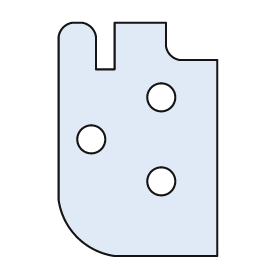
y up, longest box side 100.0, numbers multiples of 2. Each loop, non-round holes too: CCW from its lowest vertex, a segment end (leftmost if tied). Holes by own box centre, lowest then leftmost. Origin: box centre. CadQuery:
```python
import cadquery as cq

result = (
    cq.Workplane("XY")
    .moveTo(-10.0, -50.0)
    .lineTo(34.0, -50.0)
    .lineTo(34.0, 34.0)
    .lineTo(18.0, 34.0)
    .threePointArc((14.0, 36.0), (12.0, 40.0))
    .lineTo(12.0, 50.0)
    .lineTo(-10.0, 50.0)
    .lineTo(-10.0, 30.0)
    .lineTo(-18.0, 30.0)
    .lineTo(-18.0, 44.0)
    .threePointArc((-20.0, 48.0), (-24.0, 50.0))
    .lineTo(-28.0, 50.0)
    .threePointArc((-32.0, 48.0), (-34.0, 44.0))
    .lineTo(-34.0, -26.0)
    .threePointArc((-26.0, -42.0), (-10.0, -50.0))
    .close()
    .moveTo(10.0, -18.0)
    .circle(6.0)
    .moveTo(-20.0, 0.0)
    .circle(6.0)
    .moveTo(10.0, 18.0)
    .circle(6.0)
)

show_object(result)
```